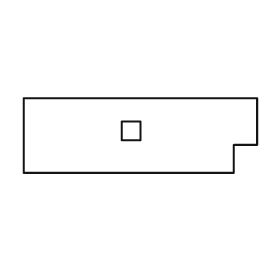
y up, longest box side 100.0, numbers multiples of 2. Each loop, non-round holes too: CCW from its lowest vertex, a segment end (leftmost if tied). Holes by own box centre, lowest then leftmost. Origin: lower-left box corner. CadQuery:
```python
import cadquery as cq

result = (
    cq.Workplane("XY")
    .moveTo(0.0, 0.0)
    .lineTo(90.0, 0.0)
    .lineTo(90.0, 12.0)
    .lineTo(100.0, 12.0)
    .lineTo(100.0, 32.0)
    .lineTo(0.0, 32.0)
    .close()
    .moveTo(42.0, 14.0)
    .lineTo(50.0, 14.0)
    .lineTo(50.0, 22.0)
    .lineTo(42.0, 22.0)
    .close()
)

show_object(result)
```